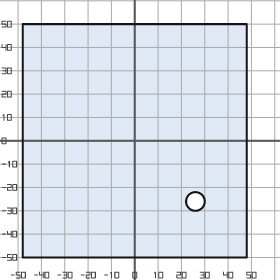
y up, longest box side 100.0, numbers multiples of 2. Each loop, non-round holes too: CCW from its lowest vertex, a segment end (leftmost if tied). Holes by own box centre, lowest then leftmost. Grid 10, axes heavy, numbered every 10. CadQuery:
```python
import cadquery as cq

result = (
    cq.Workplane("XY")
    .moveTo(-48.0, -50.0)
    .lineTo(48.0, -50.0)
    .lineTo(48.0, 50.0)
    .lineTo(-48.0, 50.0)
    .close()
    .moveTo(26.0, -26.0)
    .circle(4.0)
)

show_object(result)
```